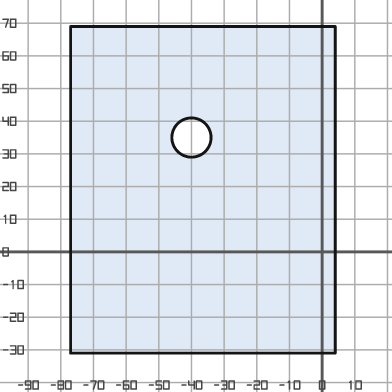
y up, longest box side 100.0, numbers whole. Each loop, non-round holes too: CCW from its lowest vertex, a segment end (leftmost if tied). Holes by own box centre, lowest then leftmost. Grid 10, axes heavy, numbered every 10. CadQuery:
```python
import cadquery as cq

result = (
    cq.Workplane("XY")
    .moveTo(-77.0, -31.0)
    .lineTo(4.0, -31.0)
    .lineTo(4.0, 69.0)
    .lineTo(-77.0, 69.0)
    .close()
    .moveTo(-40.0, 35.0)
    .circle(6.0)
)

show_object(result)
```